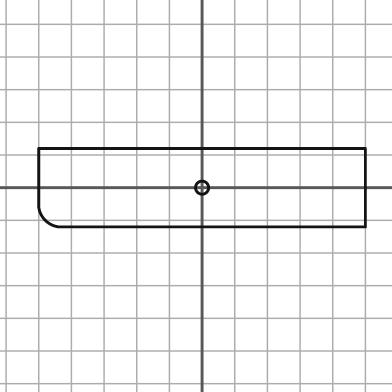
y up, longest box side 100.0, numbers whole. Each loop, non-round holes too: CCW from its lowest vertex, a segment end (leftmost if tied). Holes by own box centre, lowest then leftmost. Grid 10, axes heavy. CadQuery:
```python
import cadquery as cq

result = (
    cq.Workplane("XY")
    .moveTo(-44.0, -12.0)
    .lineTo(50.0, -12.0)
    .lineTo(50.0, 12.0)
    .lineTo(-50.0, 12.0)
    .lineTo(-50.0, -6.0)
    .threePointArc((-48.0, -10.0), (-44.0, -12.0))
    .close()
    .moveTo(0.0, 0.0)
    .circle(2.0)
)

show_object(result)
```